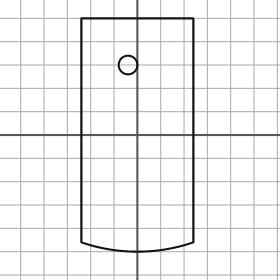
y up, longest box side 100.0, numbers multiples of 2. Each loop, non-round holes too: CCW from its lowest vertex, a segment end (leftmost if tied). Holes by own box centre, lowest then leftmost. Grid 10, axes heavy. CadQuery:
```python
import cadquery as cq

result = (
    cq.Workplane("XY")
    .moveTo(-24.0, -46.0)
    .threePointArc((0.0, -50.0), (24.0, -46.0))
    .lineTo(24.0, 50.0)
    .lineTo(-24.0, 50.0)
    .close()
    .moveTo(-4.0, 30.0)
    .circle(4.0)
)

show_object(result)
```